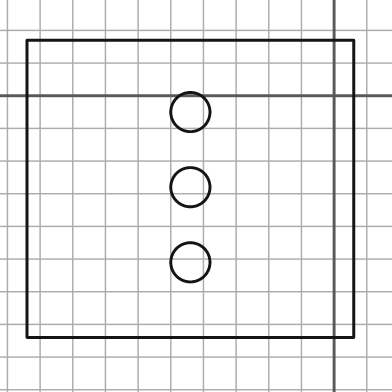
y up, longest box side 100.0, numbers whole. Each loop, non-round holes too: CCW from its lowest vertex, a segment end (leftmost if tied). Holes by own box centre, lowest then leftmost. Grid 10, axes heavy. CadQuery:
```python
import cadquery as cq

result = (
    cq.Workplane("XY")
    .moveTo(-94.0, -74.0)
    .lineTo(6.0, -74.0)
    .lineTo(6.0, 17.0)
    .lineTo(-94.0, 17.0)
    .close()
    .moveTo(-44.0, -51.0)
    .circle(6.0)
    .moveTo(-44.0, -28.0)
    .circle(6.0)
    .moveTo(-44.0, -5.0)
    .circle(6.0)
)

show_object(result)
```